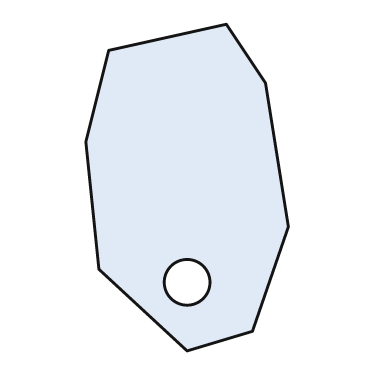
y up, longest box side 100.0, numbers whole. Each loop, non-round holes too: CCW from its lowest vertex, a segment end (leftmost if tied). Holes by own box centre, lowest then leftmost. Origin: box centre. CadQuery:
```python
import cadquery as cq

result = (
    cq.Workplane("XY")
    .moveTo(0.0, -50.0)
    .lineTo(20.0, -44.0)
    .lineTo(31.0, -12.0)
    .lineTo(24.0, 32.0)
    .lineTo(12.0, 50.0)
    .lineTo(-24.0, 42.0)
    .lineTo(-31.0, 14.0)
    .lineTo(-27.0, -25.0)
    .close()
    .moveTo(0.0, -29.0)
    .circle(7.0)
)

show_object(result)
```